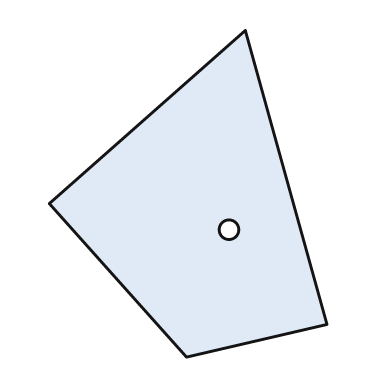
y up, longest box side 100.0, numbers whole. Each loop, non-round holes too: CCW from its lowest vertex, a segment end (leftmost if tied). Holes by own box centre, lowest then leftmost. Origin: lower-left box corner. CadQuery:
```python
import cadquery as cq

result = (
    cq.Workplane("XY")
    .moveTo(42.0, 0.0)
    .lineTo(85.0, 10.0)
    .lineTo(60.0, 100.0)
    .lineTo(0.0, 47.0)
    .close()
    .moveTo(55.0, 39.0)
    .circle(3.0)
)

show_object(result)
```